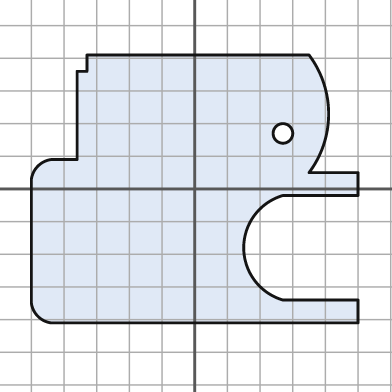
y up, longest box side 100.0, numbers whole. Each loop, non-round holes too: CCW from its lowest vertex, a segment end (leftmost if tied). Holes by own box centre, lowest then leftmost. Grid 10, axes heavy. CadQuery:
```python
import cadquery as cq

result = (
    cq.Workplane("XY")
    .moveTo(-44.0, -41.0)
    .lineTo(50.0, -41.0)
    .lineTo(50.0, -34.0)
    .lineTo(27.0, -34.0)
    .threePointArc((15.0, -18.0), (27.0, -2.0))
    .lineTo(50.0, -2.0)
    .lineTo(50.0, 5.0)
    .lineTo(35.0, 5.0)
    .threePointArc((41.0, 23.0), (35.0, 41.0))
    .lineTo(-33.0, 41.0)
    .lineTo(-33.0, 36.0)
    .lineTo(-36.0, 36.0)
    .lineTo(-36.0, 9.0)
    .lineTo(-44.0, 9.0)
    .threePointArc((-48.0, 7.0), (-50.0, 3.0))
    .lineTo(-50.0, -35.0)
    .threePointArc((-48.0, -39.0), (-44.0, -41.0))
    .close()
    .moveTo(27.0, 17.0)
    .circle(3.0)
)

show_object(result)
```